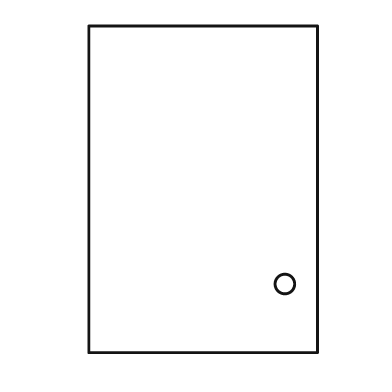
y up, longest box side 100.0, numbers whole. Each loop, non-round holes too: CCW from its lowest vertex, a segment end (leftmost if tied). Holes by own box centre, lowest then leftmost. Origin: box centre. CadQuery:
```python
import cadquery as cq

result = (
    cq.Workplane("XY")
    .moveTo(-35.0, -50.0)
    .lineTo(35.0, -50.0)
    .lineTo(35.0, 50.0)
    .lineTo(-35.0, 50.0)
    .close()
    .moveTo(25.0, -29.0)
    .circle(3.0)
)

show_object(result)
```